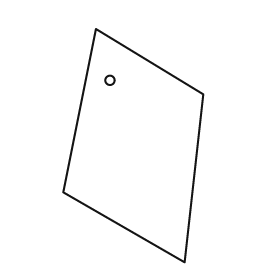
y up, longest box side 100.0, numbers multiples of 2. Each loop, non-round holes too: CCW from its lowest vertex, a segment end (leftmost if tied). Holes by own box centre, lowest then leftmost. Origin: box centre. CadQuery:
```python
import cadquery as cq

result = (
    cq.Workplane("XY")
    .moveTo(22.0, -50.0)
    .lineTo(30.0, 22.0)
    .lineTo(-16.0, 50.0)
    .lineTo(-30.0, -20.0)
    .close()
    .moveTo(-10.0, 28.0)
    .circle(2.0)
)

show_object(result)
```